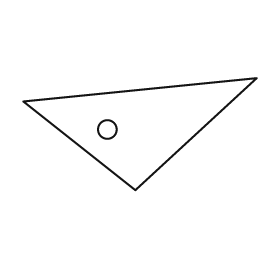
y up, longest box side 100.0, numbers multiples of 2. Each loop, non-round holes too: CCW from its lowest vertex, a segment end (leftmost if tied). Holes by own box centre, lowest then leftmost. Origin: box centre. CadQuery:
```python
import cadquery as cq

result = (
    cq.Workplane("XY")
    .moveTo(-2.0, -24.0)
    .lineTo(50.0, 24.0)
    .lineTo(-50.0, 14.0)
    .close()
    .moveTo(-14.0, 2.0)
    .circle(4.0)
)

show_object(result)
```